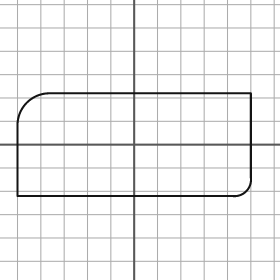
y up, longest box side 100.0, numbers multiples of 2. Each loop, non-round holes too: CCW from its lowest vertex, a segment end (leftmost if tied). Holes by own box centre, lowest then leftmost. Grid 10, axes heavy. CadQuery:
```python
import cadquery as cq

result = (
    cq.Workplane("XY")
    .moveTo(-50.0, -22.0)
    .lineTo(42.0, -22.0)
    .threePointArc((48.0, -20.0), (50.0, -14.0))
    .lineTo(50.0, 22.0)
    .lineTo(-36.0, 22.0)
    .threePointArc((-46.0, 18.0), (-50.0, 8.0))
    .close()
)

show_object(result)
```